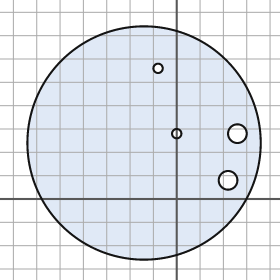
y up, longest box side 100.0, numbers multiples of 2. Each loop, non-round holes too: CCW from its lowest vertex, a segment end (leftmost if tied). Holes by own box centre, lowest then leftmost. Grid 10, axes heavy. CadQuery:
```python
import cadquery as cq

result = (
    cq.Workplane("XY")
    .moveTo(-14.0, 24.0)
    .circle(50.0)
    .moveTo(22.0, 8.0)
    .circle(4.0)
    .moveTo(0.0, 28.0)
    .circle(2.0)
    .moveTo(26.0, 28.0)
    .circle(4.0)
    .moveTo(-8.0, 56.0)
    .circle(2.0)
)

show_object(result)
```